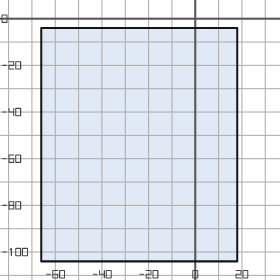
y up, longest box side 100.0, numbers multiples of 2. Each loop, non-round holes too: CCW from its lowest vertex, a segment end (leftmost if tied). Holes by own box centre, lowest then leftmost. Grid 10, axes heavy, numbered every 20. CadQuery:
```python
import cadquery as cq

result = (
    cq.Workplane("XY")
    .moveTo(-66.0, -104.0)
    .lineTo(18.0, -104.0)
    .lineTo(18.0, -4.0)
    .lineTo(-66.0, -4.0)
    .close()
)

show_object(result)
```